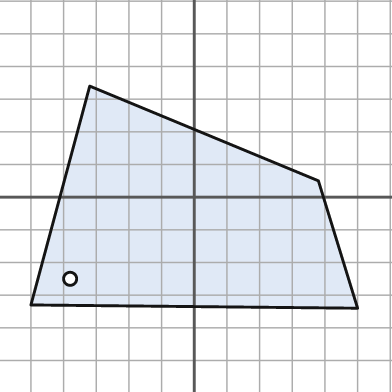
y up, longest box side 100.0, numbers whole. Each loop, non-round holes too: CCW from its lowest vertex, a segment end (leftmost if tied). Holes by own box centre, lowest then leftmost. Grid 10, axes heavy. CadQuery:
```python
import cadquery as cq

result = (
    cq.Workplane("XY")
    .moveTo(50.0, -34.0)
    .lineTo(38.0, 5.0)
    .lineTo(-32.0, 34.0)
    .lineTo(-50.0, -33.0)
    .close()
    .moveTo(-38.0, -25.0)
    .circle(2.0)
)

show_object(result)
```